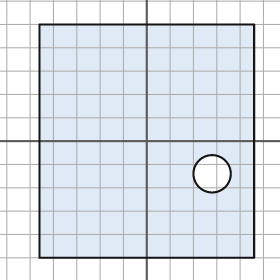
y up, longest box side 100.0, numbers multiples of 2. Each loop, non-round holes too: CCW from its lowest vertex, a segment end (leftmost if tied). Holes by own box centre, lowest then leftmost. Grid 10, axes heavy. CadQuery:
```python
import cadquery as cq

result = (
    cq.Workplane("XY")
    .moveTo(-46.0, -50.0)
    .lineTo(46.0, -50.0)
    .lineTo(46.0, 50.0)
    .lineTo(-46.0, 50.0)
    .close()
    .moveTo(28.0, -14.0)
    .circle(8.0)
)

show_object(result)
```